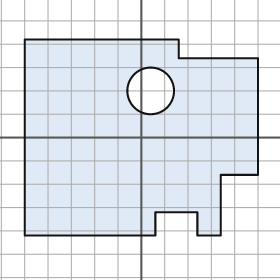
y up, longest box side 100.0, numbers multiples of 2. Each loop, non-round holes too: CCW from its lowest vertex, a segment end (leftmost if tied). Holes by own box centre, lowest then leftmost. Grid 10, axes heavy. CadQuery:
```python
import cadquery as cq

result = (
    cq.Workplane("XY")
    .moveTo(-50.0, -42.0)
    .lineTo(6.0, -42.0)
    .lineTo(6.0, -32.0)
    .lineTo(24.0, -32.0)
    .lineTo(24.0, -42.0)
    .lineTo(34.0, -42.0)
    .lineTo(34.0, -16.0)
    .lineTo(50.0, -16.0)
    .lineTo(50.0, 34.0)
    .lineTo(16.0, 34.0)
    .lineTo(16.0, 42.0)
    .lineTo(-50.0, 42.0)
    .close()
    .moveTo(4.0, 20.0)
    .circle(10.0)
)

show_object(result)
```